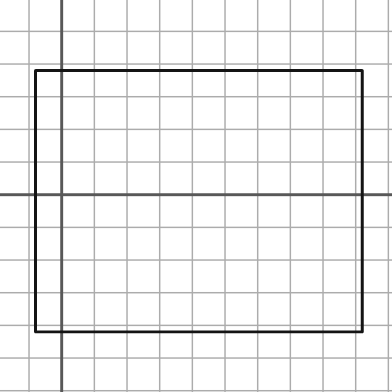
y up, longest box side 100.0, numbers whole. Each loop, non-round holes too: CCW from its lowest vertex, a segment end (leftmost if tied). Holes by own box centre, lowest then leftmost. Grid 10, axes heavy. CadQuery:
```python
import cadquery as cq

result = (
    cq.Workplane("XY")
    .moveTo(-8.0, -42.0)
    .lineTo(92.0, -42.0)
    .lineTo(92.0, 38.0)
    .lineTo(-8.0, 38.0)
    .close()
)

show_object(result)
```